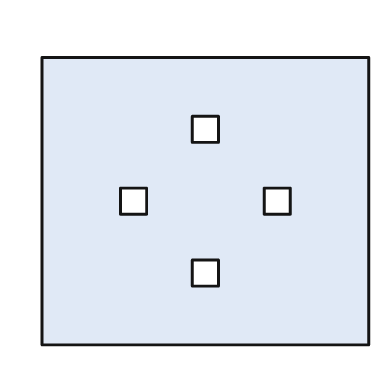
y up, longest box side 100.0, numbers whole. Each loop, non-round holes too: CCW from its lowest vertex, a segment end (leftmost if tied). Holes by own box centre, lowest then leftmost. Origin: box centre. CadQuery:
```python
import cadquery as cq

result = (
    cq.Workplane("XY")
    .moveTo(-50.0, -44.0)
    .lineTo(50.0, -44.0)
    .lineTo(50.0, 44.0)
    .lineTo(-50.0, 44.0)
    .close()
    .moveTo(-4.0, -26.0)
    .lineTo(4.0, -26.0)
    .lineTo(4.0, -18.0)
    .lineTo(-4.0, -18.0)
    .close()
    .moveTo(-26.0, -4.0)
    .lineTo(-18.0, -4.0)
    .lineTo(-18.0, 4.0)
    .lineTo(-26.0, 4.0)
    .close()
    .moveTo(18.0, -4.0)
    .lineTo(26.0, -4.0)
    .lineTo(26.0, 4.0)
    .lineTo(18.0, 4.0)
    .close()
    .moveTo(-4.0, 18.0)
    .lineTo(4.0, 18.0)
    .lineTo(4.0, 26.0)
    .lineTo(-4.0, 26.0)
    .close()
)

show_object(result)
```